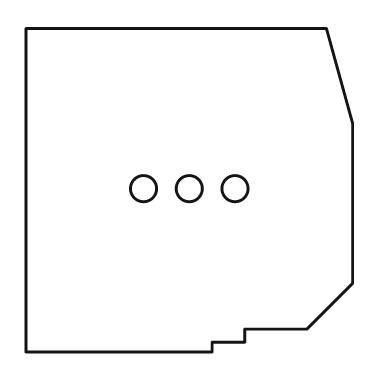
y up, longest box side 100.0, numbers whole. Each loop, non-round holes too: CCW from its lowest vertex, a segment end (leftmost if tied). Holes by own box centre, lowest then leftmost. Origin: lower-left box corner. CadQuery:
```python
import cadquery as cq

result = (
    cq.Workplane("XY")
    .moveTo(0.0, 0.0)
    .lineTo(57.0, 0.0)
    .lineTo(57.0, 3.0)
    .lineTo(67.0, 3.0)
    .lineTo(67.0, 7.0)
    .lineTo(86.0, 7.0)
    .lineTo(100.0, 21.0)
    .lineTo(100.0, 70.0)
    .lineTo(92.0, 99.0)
    .lineTo(0.0, 99.0)
    .close()
    .moveTo(36.0, 50.0)
    .circle(4.0)
    .moveTo(50.0, 50.0)
    .circle(4.0)
    .moveTo(64.0, 50.0)
    .circle(4.0)
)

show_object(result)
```